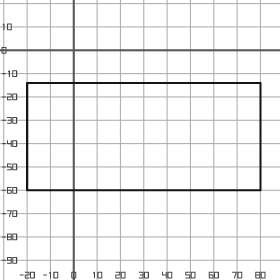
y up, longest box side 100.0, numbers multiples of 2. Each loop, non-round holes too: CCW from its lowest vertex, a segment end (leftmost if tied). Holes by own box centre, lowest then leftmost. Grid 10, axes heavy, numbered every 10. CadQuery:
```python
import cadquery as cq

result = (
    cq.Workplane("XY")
    .moveTo(-20.0, -60.0)
    .lineTo(80.0, -60.0)
    .lineTo(80.0, -14.0)
    .lineTo(-20.0, -14.0)
    .close()
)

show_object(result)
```